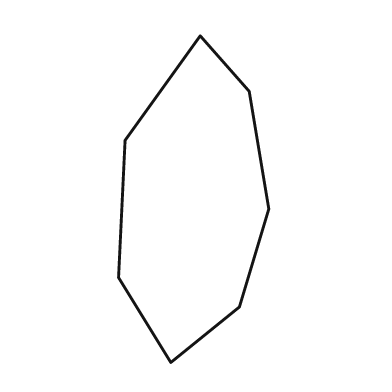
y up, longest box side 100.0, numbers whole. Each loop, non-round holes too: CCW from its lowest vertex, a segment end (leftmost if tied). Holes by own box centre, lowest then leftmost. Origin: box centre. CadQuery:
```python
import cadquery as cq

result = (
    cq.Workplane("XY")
    .moveTo(-7.0, -50.0)
    .lineTo(14.0, -33.0)
    .lineTo(23.0, -3.0)
    .lineTo(17.0, 33.0)
    .lineTo(2.0, 50.0)
    .lineTo(-21.0, 18.0)
    .lineTo(-23.0, -24.0)
    .close()
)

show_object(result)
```